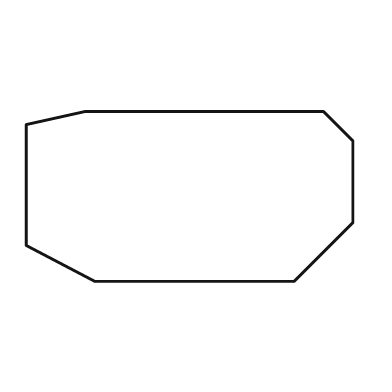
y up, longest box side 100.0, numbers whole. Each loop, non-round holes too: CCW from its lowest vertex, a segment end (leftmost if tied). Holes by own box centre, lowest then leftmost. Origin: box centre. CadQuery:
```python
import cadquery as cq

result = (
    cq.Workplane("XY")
    .moveTo(-29.0, -26.0)
    .lineTo(32.0, -26.0)
    .lineTo(50.0, -8.0)
    .lineTo(50.0, 17.0)
    .lineTo(41.0, 26.0)
    .lineTo(-32.0, 26.0)
    .lineTo(-50.0, 22.0)
    .lineTo(-50.0, -15.0)
    .close()
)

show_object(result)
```